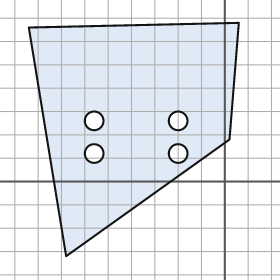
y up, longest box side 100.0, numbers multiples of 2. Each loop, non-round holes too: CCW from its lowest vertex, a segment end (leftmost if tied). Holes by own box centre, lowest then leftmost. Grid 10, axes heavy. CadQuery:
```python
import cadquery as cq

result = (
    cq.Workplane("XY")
    .moveTo(-68.0, -32.0)
    .lineTo(2.0, 18.0)
    .lineTo(6.0, 68.0)
    .lineTo(-84.0, 66.0)
    .close()
    .moveTo(-56.0, 12.0)
    .circle(4.0)
    .moveTo(-20.0, 12.0)
    .circle(4.0)
    .moveTo(-56.0, 26.0)
    .circle(4.0)
    .moveTo(-20.0, 26.0)
    .circle(4.0)
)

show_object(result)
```